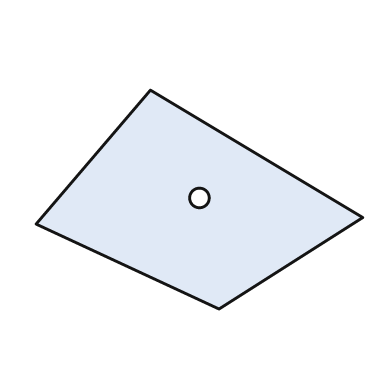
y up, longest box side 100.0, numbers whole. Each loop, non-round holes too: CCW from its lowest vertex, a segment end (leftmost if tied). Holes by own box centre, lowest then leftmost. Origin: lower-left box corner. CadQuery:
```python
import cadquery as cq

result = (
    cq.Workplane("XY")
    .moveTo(56.0, 0.0)
    .lineTo(100.0, 28.0)
    .lineTo(35.0, 67.0)
    .lineTo(0.0, 26.0)
    .close()
    .moveTo(50.0, 34.0)
    .circle(3.0)
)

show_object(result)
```